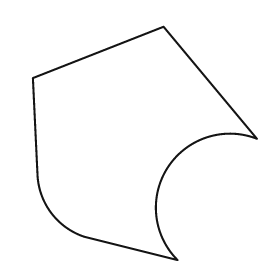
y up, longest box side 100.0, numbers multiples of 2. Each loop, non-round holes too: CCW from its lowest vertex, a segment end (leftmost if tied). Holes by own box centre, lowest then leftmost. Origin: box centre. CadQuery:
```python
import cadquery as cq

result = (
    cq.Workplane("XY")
    .moveTo(14.0, -50.0)
    .threePointArc((10.0, -10.0), (48.0, 2.0))
    .lineTo(8.0, 50.0)
    .lineTo(-48.0, 28.0)
    .lineTo(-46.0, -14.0)
    .threePointArc((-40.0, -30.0), (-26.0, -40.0))
    .close()
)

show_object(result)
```